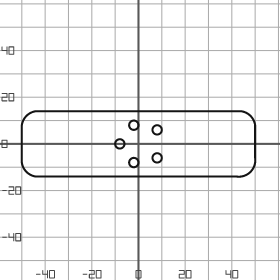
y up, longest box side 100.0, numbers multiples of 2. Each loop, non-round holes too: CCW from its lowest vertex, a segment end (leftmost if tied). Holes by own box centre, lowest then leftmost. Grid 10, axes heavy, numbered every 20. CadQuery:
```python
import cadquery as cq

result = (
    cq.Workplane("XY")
    .moveTo(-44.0, -14.0)
    .lineTo(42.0, -14.0)
    .threePointArc((48.0, -12.0), (50.0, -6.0))
    .lineTo(50.0, 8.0)
    .threePointArc((48.0, 12.0), (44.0, 14.0))
    .lineTo(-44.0, 14.0)
    .threePointArc((-48.0, 12.0), (-50.0, 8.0))
    .lineTo(-50.0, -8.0)
    .threePointArc((-48.0, -12.0), (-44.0, -14.0))
    .close()
    .moveTo(-2.0, -8.0)
    .circle(2.0)
    .moveTo(8.0, -6.0)
    .circle(2.0)
    .moveTo(-8.0, 0.0)
    .circle(2.0)
    .moveTo(8.0, 6.0)
    .circle(2.0)
    .moveTo(-2.0, 8.0)
    .circle(2.0)
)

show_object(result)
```